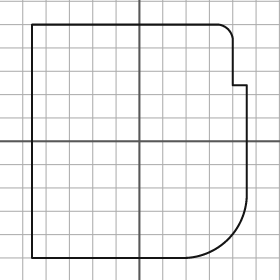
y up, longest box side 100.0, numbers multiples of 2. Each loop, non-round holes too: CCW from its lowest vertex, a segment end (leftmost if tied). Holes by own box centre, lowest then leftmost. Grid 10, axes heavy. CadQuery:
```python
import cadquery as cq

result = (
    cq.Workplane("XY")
    .moveTo(-46.0, -50.0)
    .lineTo(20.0, -50.0)
    .threePointArc((38.0, -42.0), (46.0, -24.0))
    .lineTo(46.0, 24.0)
    .lineTo(40.0, 24.0)
    .lineTo(40.0, 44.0)
    .threePointArc((38.0, 48.0), (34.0, 50.0))
    .lineTo(-46.0, 50.0)
    .close()
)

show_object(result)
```